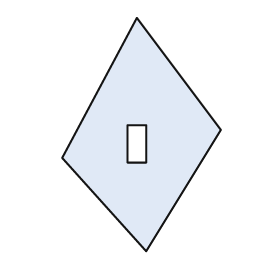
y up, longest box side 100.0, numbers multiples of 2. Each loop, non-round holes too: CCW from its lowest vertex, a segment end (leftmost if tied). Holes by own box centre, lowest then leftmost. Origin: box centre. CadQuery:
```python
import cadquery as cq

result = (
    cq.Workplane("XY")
    .moveTo(2.0, -50.0)
    .lineTo(34.0, 2.0)
    .lineTo(-2.0, 50.0)
    .lineTo(-34.0, -10.0)
    .close()
    .moveTo(-6.0, -12.0)
    .lineTo(2.0, -12.0)
    .lineTo(2.0, 4.0)
    .lineTo(-6.0, 4.0)
    .close()
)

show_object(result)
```